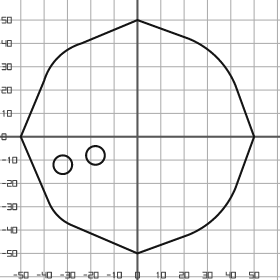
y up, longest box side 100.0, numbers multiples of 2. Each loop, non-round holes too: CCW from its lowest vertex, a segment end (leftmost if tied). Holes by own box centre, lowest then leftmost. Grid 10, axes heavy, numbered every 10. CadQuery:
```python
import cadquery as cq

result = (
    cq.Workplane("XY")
    .moveTo(0.0, -50.0)
    .lineTo(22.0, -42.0)
    .threePointArc((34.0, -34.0), (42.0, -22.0))
    .lineTo(50.0, 0.0)
    .lineTo(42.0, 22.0)
    .threePointArc((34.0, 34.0), (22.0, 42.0))
    .lineTo(0.0, 50.0)
    .lineTo(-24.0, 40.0)
    .threePointArc((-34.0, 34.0), (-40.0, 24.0))
    .lineTo(-50.0, 0.0)
    .lineTo(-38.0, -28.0)
    .threePointArc((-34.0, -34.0), (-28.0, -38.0))
    .close()
    .moveTo(-32.0, -12.0)
    .circle(4.0)
    .moveTo(-18.0, -8.0)
    .circle(4.0)
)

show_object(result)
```